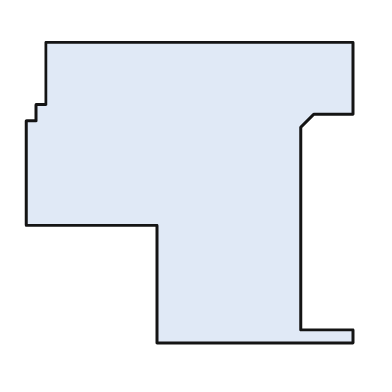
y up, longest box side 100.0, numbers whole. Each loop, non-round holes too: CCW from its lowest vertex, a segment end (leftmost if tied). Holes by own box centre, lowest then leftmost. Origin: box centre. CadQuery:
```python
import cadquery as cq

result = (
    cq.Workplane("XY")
    .moveTo(-10.0, -46.0)
    .lineTo(50.0, -46.0)
    .lineTo(50.0, -42.0)
    .lineTo(34.0, -42.0)
    .lineTo(34.0, 20.0)
    .lineTo(38.0, 24.0)
    .lineTo(50.0, 24.0)
    .lineTo(50.0, 46.0)
    .lineTo(-44.0, 46.0)
    .lineTo(-44.0, 27.0)
    .lineTo(-47.0, 27.0)
    .lineTo(-47.0, 22.0)
    .lineTo(-50.0, 22.0)
    .lineTo(-50.0, -10.0)
    .lineTo(-10.0, -10.0)
    .close()
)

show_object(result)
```